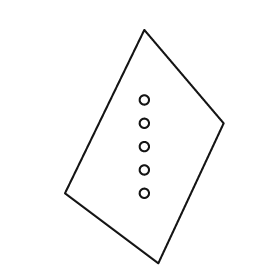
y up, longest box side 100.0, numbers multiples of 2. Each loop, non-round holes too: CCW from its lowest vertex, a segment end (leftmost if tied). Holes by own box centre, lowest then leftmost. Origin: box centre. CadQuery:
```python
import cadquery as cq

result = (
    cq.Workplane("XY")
    .moveTo(6.0, -50.0)
    .lineTo(34.0, 10.0)
    .lineTo(0.0, 50.0)
    .lineTo(-34.0, -20.0)
    .close()
    .moveTo(0.0, -20.0)
    .circle(2.0)
    .moveTo(0.0, -10.0)
    .circle(2.0)
    .moveTo(0.0, 0.0)
    .circle(2.0)
    .moveTo(0.0, 10.0)
    .circle(2.0)
    .moveTo(0.0, 20.0)
    .circle(2.0)
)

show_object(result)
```